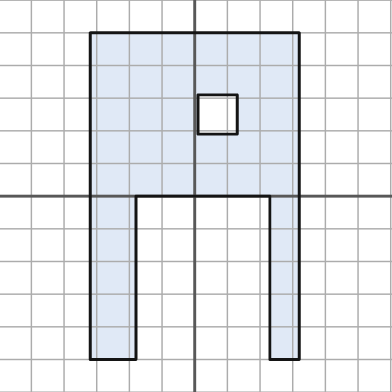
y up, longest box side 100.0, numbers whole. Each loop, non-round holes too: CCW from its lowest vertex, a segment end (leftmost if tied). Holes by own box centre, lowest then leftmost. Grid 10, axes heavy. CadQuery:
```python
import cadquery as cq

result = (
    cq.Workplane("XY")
    .moveTo(-32.0, -50.0)
    .lineTo(-18.0, -50.0)
    .lineTo(-18.0, 0.0)
    .lineTo(23.0, 0.0)
    .lineTo(23.0, -50.0)
    .lineTo(32.0, -50.0)
    .lineTo(32.0, 50.0)
    .lineTo(-32.0, 50.0)
    .close()
    .moveTo(1.0, 19.0)
    .lineTo(13.0, 19.0)
    .lineTo(13.0, 31.0)
    .lineTo(1.0, 31.0)
    .close()
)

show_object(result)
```